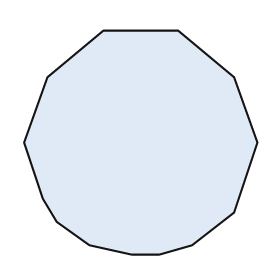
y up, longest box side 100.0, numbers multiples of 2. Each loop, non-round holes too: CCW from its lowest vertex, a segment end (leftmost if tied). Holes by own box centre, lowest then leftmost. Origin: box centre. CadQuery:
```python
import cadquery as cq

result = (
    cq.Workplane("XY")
    .moveTo(-4.0, -48.0)
    .lineTo(8.0, -48.0)
    .lineTo(22.0, -44.0)
    .lineTo(40.0, -30.0)
    .lineTo(50.0, 0.0)
    .lineTo(40.0, 28.0)
    .lineTo(16.0, 48.0)
    .lineTo(-16.0, 48.0)
    .lineTo(-40.0, 28.0)
    .lineTo(-50.0, 0.0)
    .lineTo(-42.0, -24.0)
    .lineTo(-36.0, -34.0)
    .lineTo(-22.0, -44.0)
    .close()
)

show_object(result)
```